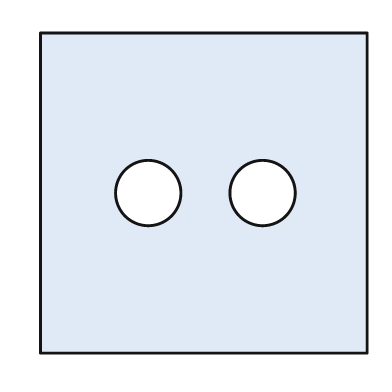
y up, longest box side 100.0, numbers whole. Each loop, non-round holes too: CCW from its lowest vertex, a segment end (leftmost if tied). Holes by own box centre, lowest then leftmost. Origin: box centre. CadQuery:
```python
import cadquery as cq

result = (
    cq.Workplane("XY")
    .moveTo(-50.0, -49.0)
    .lineTo(50.0, -49.0)
    .lineTo(50.0, 49.0)
    .lineTo(-50.0, 49.0)
    .close()
    .moveTo(-17.0, 0.0)
    .circle(10.0)
    .moveTo(18.0, 0.0)
    .circle(10.0)
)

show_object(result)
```